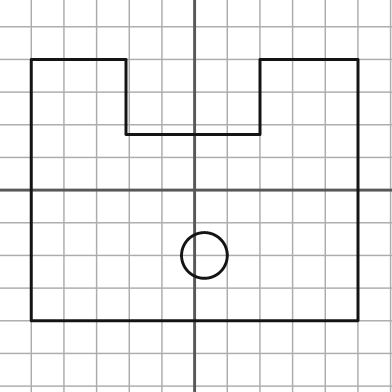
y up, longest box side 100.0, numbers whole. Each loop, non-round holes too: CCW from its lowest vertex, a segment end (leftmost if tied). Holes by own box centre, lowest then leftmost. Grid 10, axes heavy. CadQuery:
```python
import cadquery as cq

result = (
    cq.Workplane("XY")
    .moveTo(-50.0, -40.0)
    .lineTo(50.0, -40.0)
    .lineTo(50.0, 40.0)
    .lineTo(20.0, 40.0)
    .lineTo(20.0, 17.0)
    .lineTo(-21.0, 17.0)
    .lineTo(-21.0, 40.0)
    .lineTo(-50.0, 40.0)
    .close()
    .moveTo(3.0, -20.0)
    .circle(7.0)
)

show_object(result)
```